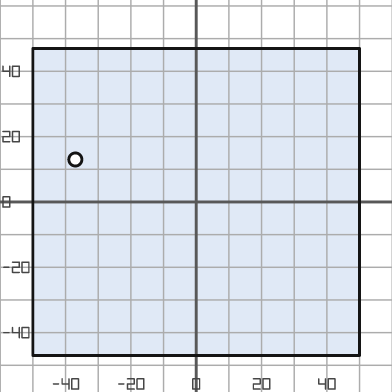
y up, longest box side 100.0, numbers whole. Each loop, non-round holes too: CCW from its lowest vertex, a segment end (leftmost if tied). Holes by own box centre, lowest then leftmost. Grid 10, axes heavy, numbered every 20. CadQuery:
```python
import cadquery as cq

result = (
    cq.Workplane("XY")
    .moveTo(-50.0, -47.0)
    .lineTo(50.0, -47.0)
    .lineTo(50.0, 47.0)
    .lineTo(-50.0, 47.0)
    .close()
    .moveTo(-37.0, 13.0)
    .circle(2.0)
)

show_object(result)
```